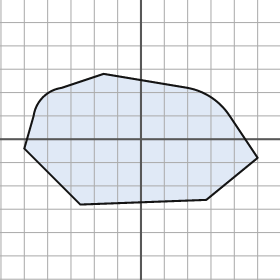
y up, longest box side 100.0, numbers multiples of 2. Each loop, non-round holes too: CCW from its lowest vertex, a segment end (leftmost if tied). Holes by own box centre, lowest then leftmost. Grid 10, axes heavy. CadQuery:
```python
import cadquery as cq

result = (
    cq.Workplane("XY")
    .moveTo(-26.0, -28.0)
    .lineTo(28.0, -26.0)
    .lineTo(50.0, -8.0)
    .lineTo(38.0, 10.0)
    .threePointArc((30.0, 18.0), (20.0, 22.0))
    .lineTo(-16.0, 28.0)
    .lineTo(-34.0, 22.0)
    .threePointArc((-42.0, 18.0), (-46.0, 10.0))
    .lineTo(-50.0, -4.0)
    .close()
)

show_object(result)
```